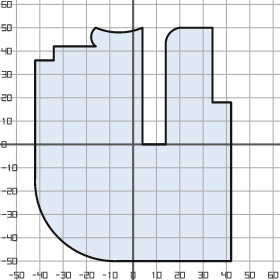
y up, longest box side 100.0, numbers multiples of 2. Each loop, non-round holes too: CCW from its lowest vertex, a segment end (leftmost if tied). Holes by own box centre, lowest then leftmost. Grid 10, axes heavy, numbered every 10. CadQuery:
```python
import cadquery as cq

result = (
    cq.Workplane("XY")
    .moveTo(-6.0, -50.0)
    .lineTo(42.0, -50.0)
    .lineTo(42.0, 18.0)
    .lineTo(34.0, 18.0)
    .lineTo(34.0, 50.0)
    .lineTo(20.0, 50.0)
    .threePointArc((16.0, 48.0), (14.0, 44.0))
    .lineTo(14.0, 0.0)
    .lineTo(4.0, 0.0)
    .lineTo(4.0, 50.0)
    .threePointArc((-6.0, 48.0), (-16.0, 50.0))
    .threePointArc((-18.0, 46.0), (-16.0, 42.0))
    .lineTo(-34.0, 42.0)
    .lineTo(-34.0, 36.0)
    .lineTo(-42.0, 36.0)
    .lineTo(-42.0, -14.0)
    .threePointArc((-32.0, -40.0), (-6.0, -50.0))
    .close()
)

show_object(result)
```